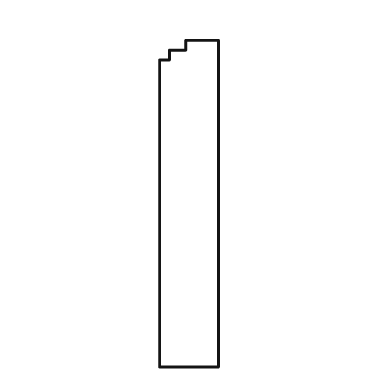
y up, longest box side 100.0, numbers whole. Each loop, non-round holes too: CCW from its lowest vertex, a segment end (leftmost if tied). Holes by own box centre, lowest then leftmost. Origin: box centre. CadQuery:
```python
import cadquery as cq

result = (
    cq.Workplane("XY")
    .moveTo(-9.0, -50.0)
    .lineTo(9.0, -50.0)
    .lineTo(9.0, 50.0)
    .lineTo(-1.0, 50.0)
    .lineTo(-1.0, 47.0)
    .lineTo(-6.0, 47.0)
    .lineTo(-6.0, 44.0)
    .lineTo(-9.0, 44.0)
    .close()
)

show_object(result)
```